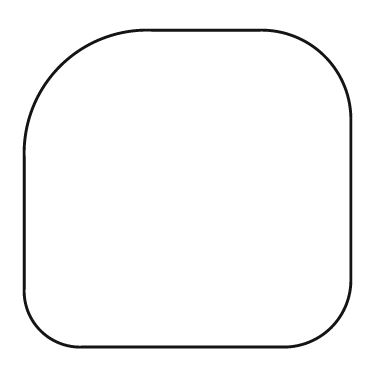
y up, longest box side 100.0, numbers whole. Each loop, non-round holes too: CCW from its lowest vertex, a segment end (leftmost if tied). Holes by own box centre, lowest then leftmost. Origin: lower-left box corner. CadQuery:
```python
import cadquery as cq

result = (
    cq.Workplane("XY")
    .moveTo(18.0, 0.0)
    .lineTo(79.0, 0.0)
    .threePointArc((94.0, 6.0), (100.0, 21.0))
    .lineTo(100.0, 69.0)
    .threePointArc((92.0, 89.0), (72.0, 97.0))
    .lineTo(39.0, 97.0)
    .threePointArc((11.0, 86.0), (0.0, 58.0))
    .lineTo(0.0, 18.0)
    .threePointArc((5.0, 5.0), (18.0, 0.0))
    .close()
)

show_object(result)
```